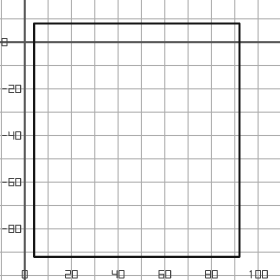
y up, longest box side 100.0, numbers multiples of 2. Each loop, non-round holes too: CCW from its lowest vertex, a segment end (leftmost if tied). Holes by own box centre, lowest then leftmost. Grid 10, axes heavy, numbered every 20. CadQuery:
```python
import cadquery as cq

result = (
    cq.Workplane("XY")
    .moveTo(4.0, -92.0)
    .lineTo(92.0, -92.0)
    .lineTo(92.0, 8.0)
    .lineTo(4.0, 8.0)
    .close()
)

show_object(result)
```